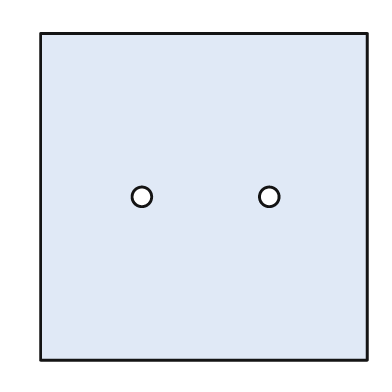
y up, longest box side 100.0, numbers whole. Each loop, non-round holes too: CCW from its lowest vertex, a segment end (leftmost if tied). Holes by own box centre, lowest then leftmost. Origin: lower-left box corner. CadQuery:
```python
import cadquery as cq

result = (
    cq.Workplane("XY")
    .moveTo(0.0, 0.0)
    .lineTo(100.0, 0.0)
    .lineTo(100.0, 100.0)
    .lineTo(0.0, 100.0)
    .close()
    .moveTo(31.0, 50.0)
    .circle(3.0)
    .moveTo(70.0, 50.0)
    .circle(3.0)
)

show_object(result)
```